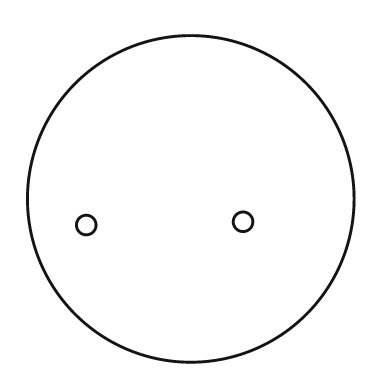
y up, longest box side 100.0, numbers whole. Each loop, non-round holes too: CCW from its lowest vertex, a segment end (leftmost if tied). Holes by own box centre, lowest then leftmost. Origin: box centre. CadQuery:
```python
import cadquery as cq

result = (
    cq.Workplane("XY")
    .moveTo(0.0, 0.0)
    .circle(50.0)
    .moveTo(-32.0, -8.0)
    .circle(3.0)
    .moveTo(16.0, -7.0)
    .circle(3.0)
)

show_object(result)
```